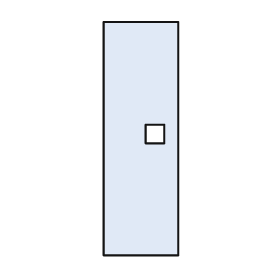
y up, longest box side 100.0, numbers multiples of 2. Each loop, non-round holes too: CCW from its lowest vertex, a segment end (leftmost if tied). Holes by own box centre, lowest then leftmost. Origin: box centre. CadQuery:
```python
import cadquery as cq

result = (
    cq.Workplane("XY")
    .moveTo(-16.0, -50.0)
    .lineTo(16.0, -50.0)
    .lineTo(16.0, 50.0)
    .lineTo(-16.0, 50.0)
    .close()
    .moveTo(2.0, -2.0)
    .lineTo(10.0, -2.0)
    .lineTo(10.0, 6.0)
    .lineTo(2.0, 6.0)
    .close()
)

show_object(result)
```